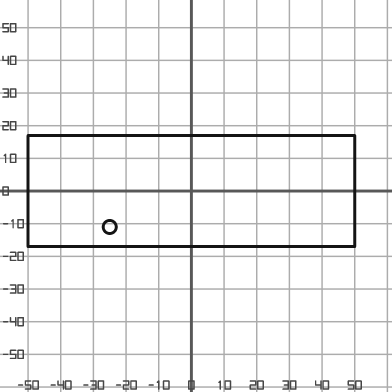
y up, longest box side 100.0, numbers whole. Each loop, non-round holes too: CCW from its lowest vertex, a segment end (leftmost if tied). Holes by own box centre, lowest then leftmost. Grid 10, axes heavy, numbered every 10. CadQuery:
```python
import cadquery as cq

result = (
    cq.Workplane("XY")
    .moveTo(-50.0, -17.0)
    .lineTo(50.0, -17.0)
    .lineTo(50.0, 17.0)
    .lineTo(-50.0, 17.0)
    .close()
    .moveTo(-25.0, -11.0)
    .circle(2.0)
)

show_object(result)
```